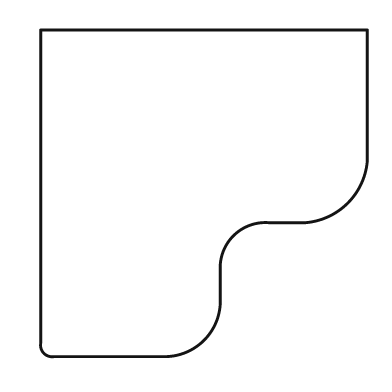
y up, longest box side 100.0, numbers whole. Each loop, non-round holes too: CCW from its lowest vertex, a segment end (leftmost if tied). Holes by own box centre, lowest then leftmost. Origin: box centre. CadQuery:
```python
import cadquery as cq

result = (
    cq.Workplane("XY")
    .moveTo(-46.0, -50.0)
    .lineTo(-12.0, -50.0)
    .threePointArc((0.0, -45.0), (5.0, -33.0))
    .lineTo(5.0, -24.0)
    .threePointArc((9.0, -13.0), (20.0, -9.0))
    .lineTo(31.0, -9.0)
    .threePointArc((44.0, -3.0), (50.0, 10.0))
    .lineTo(50.0, 50.0)
    .lineTo(-50.0, 50.0)
    .lineTo(-50.0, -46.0)
    .threePointArc((-49.0, -49.0), (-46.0, -50.0))
    .close()
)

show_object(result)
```